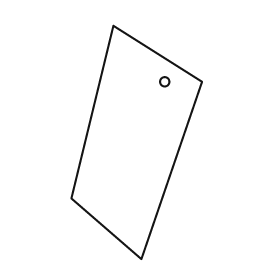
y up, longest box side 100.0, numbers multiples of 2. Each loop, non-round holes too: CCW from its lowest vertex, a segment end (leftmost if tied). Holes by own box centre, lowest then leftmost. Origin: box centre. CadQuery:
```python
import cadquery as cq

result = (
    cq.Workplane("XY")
    .moveTo(2.0, -50.0)
    .lineTo(28.0, 26.0)
    .lineTo(-10.0, 50.0)
    .lineTo(-28.0, -24.0)
    .close()
    .moveTo(12.0, 26.0)
    .circle(2.0)
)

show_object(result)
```